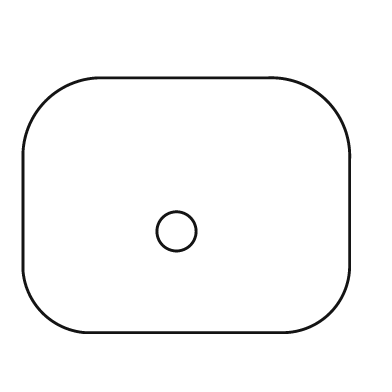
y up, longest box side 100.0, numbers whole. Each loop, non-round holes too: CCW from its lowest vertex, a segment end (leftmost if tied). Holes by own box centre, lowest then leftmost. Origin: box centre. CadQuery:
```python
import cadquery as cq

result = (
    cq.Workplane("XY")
    .moveTo(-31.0, -39.0)
    .lineTo(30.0, -39.0)
    .threePointArc((44.0, -33.0), (50.0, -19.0))
    .lineTo(50.0, 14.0)
    .threePointArc((43.0, 32.0), (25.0, 39.0))
    .lineTo(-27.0, 39.0)
    .threePointArc((-43.0, 32.0), (-50.0, 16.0))
    .lineTo(-50.0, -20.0)
    .threePointArc((-44.0, -33.0), (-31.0, -39.0))
    .close()
    .moveTo(-3.0, -8.0)
    .circle(6.0)
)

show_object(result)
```